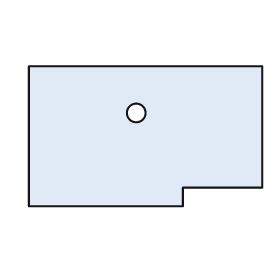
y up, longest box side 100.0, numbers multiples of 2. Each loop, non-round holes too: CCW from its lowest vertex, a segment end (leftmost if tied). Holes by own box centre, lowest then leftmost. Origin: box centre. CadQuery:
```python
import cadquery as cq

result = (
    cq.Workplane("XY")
    .moveTo(-50.0, -30.0)
    .lineTo(16.0, -30.0)
    .lineTo(16.0, -22.0)
    .lineTo(50.0, -22.0)
    .lineTo(50.0, 30.0)
    .lineTo(-50.0, 30.0)
    .close()
    .moveTo(-4.0, 10.0)
    .circle(4.0)
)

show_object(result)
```